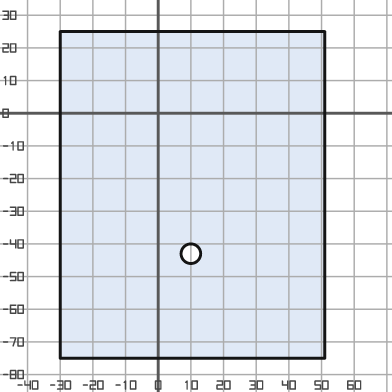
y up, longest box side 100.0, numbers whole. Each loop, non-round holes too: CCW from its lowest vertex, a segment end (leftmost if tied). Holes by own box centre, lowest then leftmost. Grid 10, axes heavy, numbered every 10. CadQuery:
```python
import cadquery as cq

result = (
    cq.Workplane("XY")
    .moveTo(-30.0, -75.0)
    .lineTo(51.0, -75.0)
    .lineTo(51.0, 25.0)
    .lineTo(-30.0, 25.0)
    .close()
    .moveTo(10.0, -43.0)
    .circle(3.0)
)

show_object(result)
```